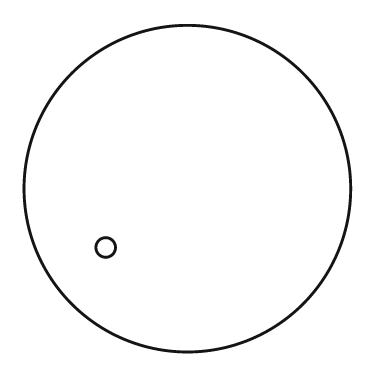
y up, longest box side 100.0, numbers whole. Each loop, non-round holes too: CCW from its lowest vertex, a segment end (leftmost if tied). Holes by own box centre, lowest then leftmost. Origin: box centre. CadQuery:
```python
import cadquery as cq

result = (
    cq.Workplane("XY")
    .moveTo(0.0, 0.0)
    .circle(50.0)
    .moveTo(-25.0, -18.0)
    .circle(3.0)
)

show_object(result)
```